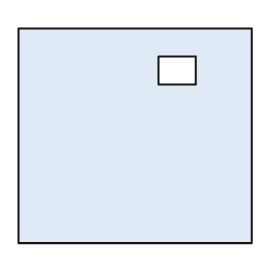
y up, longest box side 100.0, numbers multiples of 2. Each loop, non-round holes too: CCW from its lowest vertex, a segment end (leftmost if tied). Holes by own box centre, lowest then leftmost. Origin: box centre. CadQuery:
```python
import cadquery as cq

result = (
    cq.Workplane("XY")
    .moveTo(-50.0, -46.0)
    .lineTo(50.0, -46.0)
    .lineTo(50.0, 46.0)
    .lineTo(-50.0, 46.0)
    .close()
    .moveTo(10.0, 22.0)
    .lineTo(26.0, 22.0)
    .lineTo(26.0, 34.0)
    .lineTo(10.0, 34.0)
    .close()
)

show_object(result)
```